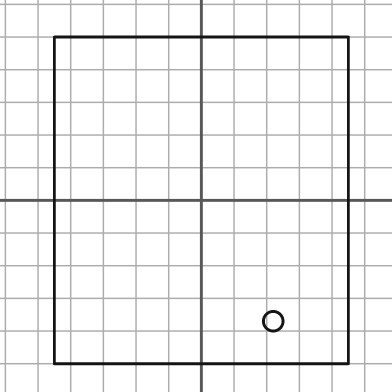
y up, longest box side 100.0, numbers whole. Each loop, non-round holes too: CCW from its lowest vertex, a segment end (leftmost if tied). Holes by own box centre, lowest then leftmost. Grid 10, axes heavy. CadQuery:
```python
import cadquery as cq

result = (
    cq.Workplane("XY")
    .moveTo(-45.0, -50.0)
    .lineTo(45.0, -50.0)
    .lineTo(45.0, 50.0)
    .lineTo(-45.0, 50.0)
    .close()
    .moveTo(22.0, -37.0)
    .circle(3.0)
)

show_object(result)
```